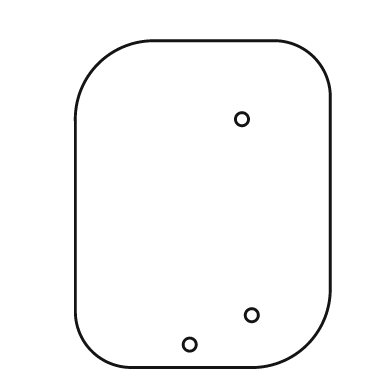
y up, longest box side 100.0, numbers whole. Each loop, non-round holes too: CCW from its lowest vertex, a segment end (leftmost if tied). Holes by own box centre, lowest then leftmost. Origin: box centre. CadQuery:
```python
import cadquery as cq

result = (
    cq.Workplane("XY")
    .moveTo(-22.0, -50.0)
    .lineTo(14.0, -50.0)
    .threePointArc((32.0, -43.0), (39.0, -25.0))
    .lineTo(39.0, 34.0)
    .threePointArc((34.0, 45.0), (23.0, 50.0))
    .lineTo(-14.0, 50.0)
    .threePointArc((-32.0, 43.0), (-39.0, 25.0))
    .lineTo(-39.0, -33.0)
    .threePointArc((-34.0, -45.0), (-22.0, -50.0))
    .close()
    .moveTo(-4.0, -43.0)
    .circle(2.0)
    .moveTo(15.0, -34.0)
    .circle(2.0)
    .moveTo(12.0, 26.0)
    .circle(2.0)
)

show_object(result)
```